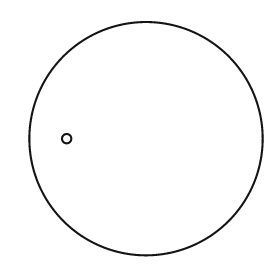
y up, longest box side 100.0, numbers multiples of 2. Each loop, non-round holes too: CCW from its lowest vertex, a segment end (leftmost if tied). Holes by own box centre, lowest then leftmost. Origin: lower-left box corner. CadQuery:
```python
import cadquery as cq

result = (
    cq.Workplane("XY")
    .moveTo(50.0, 50.0)
    .circle(50.0)
    .moveTo(16.0, 50.0)
    .circle(2.0)
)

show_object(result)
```